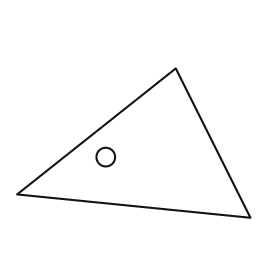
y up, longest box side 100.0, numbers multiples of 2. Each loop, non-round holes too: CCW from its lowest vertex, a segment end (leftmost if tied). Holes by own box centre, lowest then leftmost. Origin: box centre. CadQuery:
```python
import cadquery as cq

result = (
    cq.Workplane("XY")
    .moveTo(50.0, -32.0)
    .lineTo(18.0, 32.0)
    .lineTo(-50.0, -22.0)
    .close()
    .moveTo(-12.0, -6.0)
    .circle(4.0)
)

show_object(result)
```